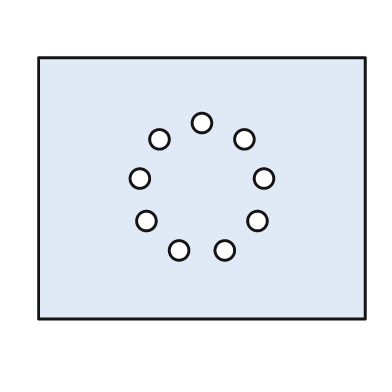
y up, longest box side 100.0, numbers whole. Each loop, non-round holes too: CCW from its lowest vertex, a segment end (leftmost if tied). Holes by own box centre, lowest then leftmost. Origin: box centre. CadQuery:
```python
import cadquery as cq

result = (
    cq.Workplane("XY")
    .moveTo(-50.0, -40.0)
    .lineTo(50.0, -40.0)
    .lineTo(50.0, 40.0)
    .lineTo(-50.0, 40.0)
    .close()
    .moveTo(-7.0, -19.0)
    .circle(3.0)
    .moveTo(7.0, -19.0)
    .circle(3.0)
    .moveTo(-17.0, -10.0)
    .circle(3.0)
    .moveTo(17.0, -10.0)
    .circle(3.0)
    .moveTo(-19.0, 3.0)
    .circle(3.0)
    .moveTo(19.0, 3.0)
    .circle(3.0)
    .moveTo(-13.0, 15.0)
    .circle(3.0)
    .moveTo(13.0, 15.0)
    .circle(3.0)
    .moveTo(0.0, 20.0)
    .circle(3.0)
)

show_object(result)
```